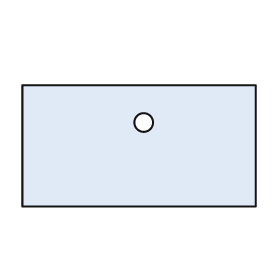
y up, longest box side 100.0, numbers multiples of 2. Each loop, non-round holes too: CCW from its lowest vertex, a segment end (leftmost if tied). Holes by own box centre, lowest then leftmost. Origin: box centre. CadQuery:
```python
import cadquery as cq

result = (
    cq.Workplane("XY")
    .moveTo(-50.0, -26.0)
    .lineTo(50.0, -26.0)
    .lineTo(50.0, 26.0)
    .lineTo(-50.0, 26.0)
    .close()
    .moveTo(2.0, 10.0)
    .circle(4.0)
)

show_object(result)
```